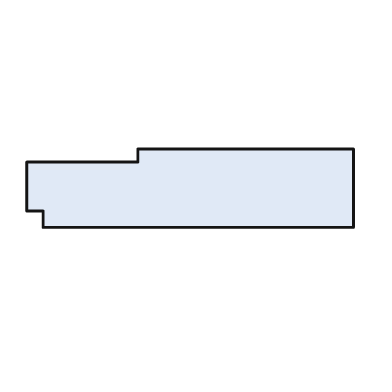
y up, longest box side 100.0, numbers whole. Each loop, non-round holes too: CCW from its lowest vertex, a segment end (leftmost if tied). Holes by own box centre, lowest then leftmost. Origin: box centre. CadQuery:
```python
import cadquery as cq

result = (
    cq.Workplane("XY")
    .moveTo(-45.0, -12.0)
    .lineTo(50.0, -12.0)
    .lineTo(50.0, 12.0)
    .lineTo(-16.0, 12.0)
    .lineTo(-16.0, 8.0)
    .lineTo(-50.0, 8.0)
    .lineTo(-50.0, -7.0)
    .lineTo(-45.0, -7.0)
    .close()
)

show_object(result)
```